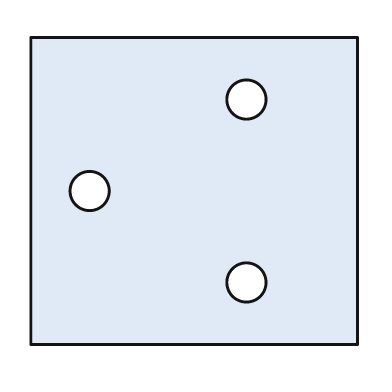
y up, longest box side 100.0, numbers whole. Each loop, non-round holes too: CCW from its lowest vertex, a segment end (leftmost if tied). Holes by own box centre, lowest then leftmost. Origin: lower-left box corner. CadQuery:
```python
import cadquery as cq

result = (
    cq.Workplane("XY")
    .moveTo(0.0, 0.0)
    .lineTo(100.0, 0.0)
    .lineTo(100.0, 94.0)
    .lineTo(0.0, 94.0)
    .close()
    .moveTo(66.0, 19.0)
    .circle(6.0)
    .moveTo(18.0, 47.0)
    .circle(6.0)
    .moveTo(66.0, 75.0)
    .circle(6.0)
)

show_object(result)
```